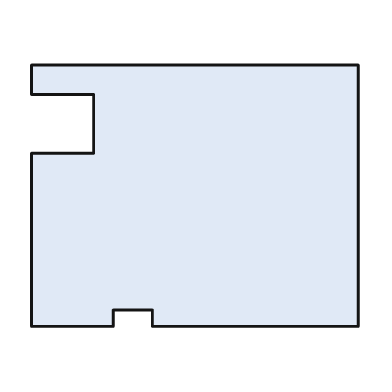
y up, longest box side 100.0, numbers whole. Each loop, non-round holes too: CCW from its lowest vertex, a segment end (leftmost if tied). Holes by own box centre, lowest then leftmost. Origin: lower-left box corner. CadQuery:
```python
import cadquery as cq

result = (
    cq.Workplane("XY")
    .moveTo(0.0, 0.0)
    .lineTo(25.0, 0.0)
    .lineTo(25.0, 5.0)
    .lineTo(37.0, 5.0)
    .lineTo(37.0, 0.0)
    .lineTo(100.0, 0.0)
    .lineTo(100.0, 80.0)
    .lineTo(0.0, 80.0)
    .lineTo(0.0, 71.0)
    .lineTo(19.0, 71.0)
    .lineTo(19.0, 53.0)
    .lineTo(0.0, 53.0)
    .close()
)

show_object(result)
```